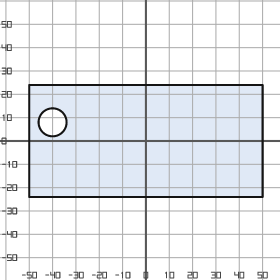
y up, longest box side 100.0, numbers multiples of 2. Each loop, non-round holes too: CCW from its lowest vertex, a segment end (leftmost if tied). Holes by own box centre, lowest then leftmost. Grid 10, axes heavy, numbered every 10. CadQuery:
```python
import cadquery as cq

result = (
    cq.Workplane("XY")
    .moveTo(-50.0, -24.0)
    .lineTo(50.0, -24.0)
    .lineTo(50.0, 24.0)
    .lineTo(-50.0, 24.0)
    .close()
    .moveTo(-40.0, 8.0)
    .circle(6.0)
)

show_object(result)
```